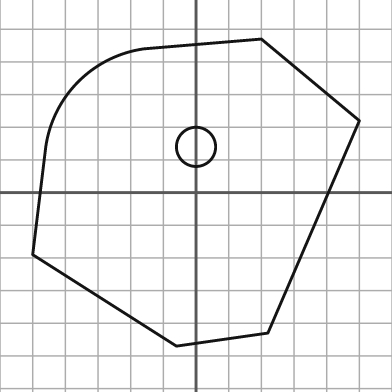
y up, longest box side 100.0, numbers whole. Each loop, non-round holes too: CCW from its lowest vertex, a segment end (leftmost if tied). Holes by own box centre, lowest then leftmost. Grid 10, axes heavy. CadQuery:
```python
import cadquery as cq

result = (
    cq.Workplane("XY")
    .moveTo(-6.0, -47.0)
    .lineTo(22.0, -43.0)
    .lineTo(50.0, 22.0)
    .lineTo(20.0, 47.0)
    .lineTo(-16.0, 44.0)
    .threePointArc((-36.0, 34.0), (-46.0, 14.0))
    .lineTo(-50.0, -19.0)
    .close()
    .moveTo(0.0, 14.0)
    .circle(6.0)
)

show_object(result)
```